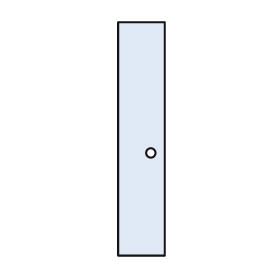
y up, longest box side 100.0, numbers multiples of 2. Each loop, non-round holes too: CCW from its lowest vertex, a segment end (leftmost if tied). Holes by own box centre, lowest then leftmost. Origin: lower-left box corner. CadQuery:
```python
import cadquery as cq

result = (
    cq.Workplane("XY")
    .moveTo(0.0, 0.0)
    .lineTo(20.0, 0.0)
    .lineTo(20.0, 100.0)
    .lineTo(0.0, 100.0)
    .close()
    .moveTo(14.0, 44.0)
    .circle(2.0)
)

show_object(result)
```